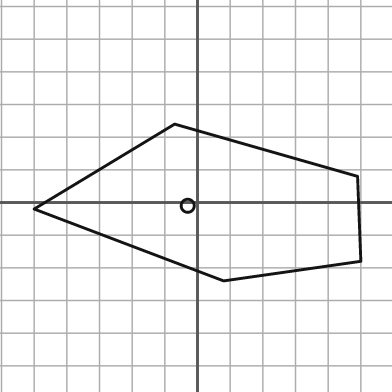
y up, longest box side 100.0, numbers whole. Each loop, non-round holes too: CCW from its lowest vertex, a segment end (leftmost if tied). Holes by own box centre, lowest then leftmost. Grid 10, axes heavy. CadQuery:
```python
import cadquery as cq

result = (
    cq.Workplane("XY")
    .moveTo(8.0, -24.0)
    .lineTo(50.0, -18.0)
    .lineTo(49.0, 8.0)
    .lineTo(-7.0, 24.0)
    .lineTo(-50.0, -2.0)
    .close()
    .moveTo(-3.0, -1.0)
    .circle(2.0)
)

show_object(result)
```